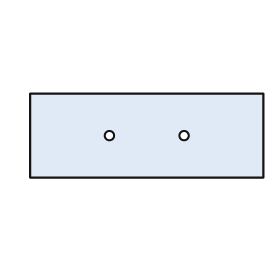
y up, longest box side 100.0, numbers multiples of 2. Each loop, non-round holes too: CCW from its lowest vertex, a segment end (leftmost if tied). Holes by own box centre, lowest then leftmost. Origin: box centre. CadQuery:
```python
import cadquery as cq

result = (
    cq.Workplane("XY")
    .moveTo(-50.0, -18.0)
    .lineTo(50.0, -18.0)
    .lineTo(50.0, 18.0)
    .lineTo(-50.0, 18.0)
    .close()
    .moveTo(-16.0, 0.0)
    .circle(2.0)
    .moveTo(16.0, 0.0)
    .circle(2.0)
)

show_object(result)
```